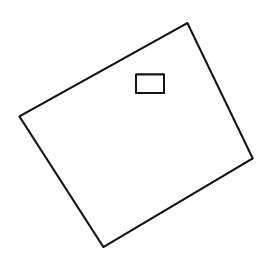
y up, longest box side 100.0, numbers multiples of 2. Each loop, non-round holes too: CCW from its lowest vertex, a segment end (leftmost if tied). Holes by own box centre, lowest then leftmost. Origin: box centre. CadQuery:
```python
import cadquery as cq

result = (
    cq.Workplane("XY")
    .moveTo(-14.0, -48.0)
    .lineTo(50.0, -10.0)
    .lineTo(22.0, 48.0)
    .lineTo(-50.0, 8.0)
    .close()
    .moveTo(0.0, 18.0)
    .lineTo(12.0, 18.0)
    .lineTo(12.0, 26.0)
    .lineTo(0.0, 26.0)
    .close()
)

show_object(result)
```